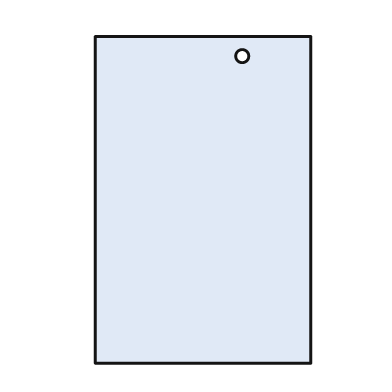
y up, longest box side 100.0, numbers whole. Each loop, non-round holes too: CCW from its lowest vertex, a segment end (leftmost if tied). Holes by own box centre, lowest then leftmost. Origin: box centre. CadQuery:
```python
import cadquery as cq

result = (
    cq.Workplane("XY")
    .moveTo(-33.0, -50.0)
    .lineTo(33.0, -50.0)
    .lineTo(33.0, 50.0)
    .lineTo(-33.0, 50.0)
    .close()
    .moveTo(12.0, 44.0)
    .circle(2.0)
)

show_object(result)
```